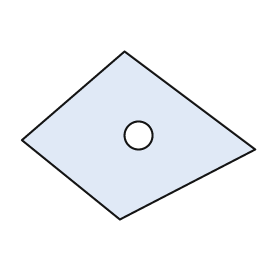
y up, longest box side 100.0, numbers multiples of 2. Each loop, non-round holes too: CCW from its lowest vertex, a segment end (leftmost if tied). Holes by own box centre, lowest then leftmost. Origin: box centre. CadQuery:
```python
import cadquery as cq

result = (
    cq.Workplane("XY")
    .moveTo(-8.0, -36.0)
    .lineTo(50.0, -6.0)
    .lineTo(-6.0, 36.0)
    .lineTo(-50.0, -2.0)
    .close()
    .moveTo(0.0, 0.0)
    .circle(6.0)
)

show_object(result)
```